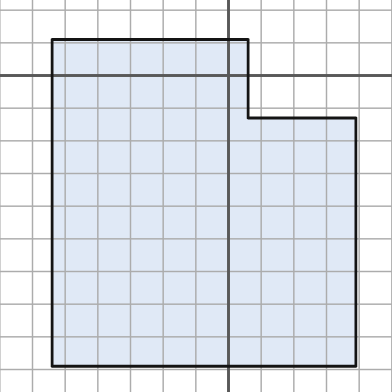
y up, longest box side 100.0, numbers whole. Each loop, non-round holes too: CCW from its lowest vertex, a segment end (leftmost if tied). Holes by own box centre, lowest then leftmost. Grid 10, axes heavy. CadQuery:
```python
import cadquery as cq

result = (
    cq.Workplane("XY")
    .moveTo(-54.0, -89.0)
    .lineTo(39.0, -89.0)
    .lineTo(39.0, -13.0)
    .lineTo(6.0, -13.0)
    .lineTo(6.0, 11.0)
    .lineTo(-54.0, 11.0)
    .close()
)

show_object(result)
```